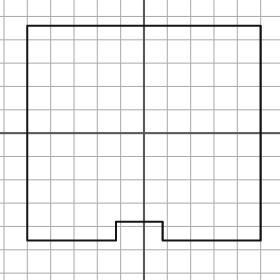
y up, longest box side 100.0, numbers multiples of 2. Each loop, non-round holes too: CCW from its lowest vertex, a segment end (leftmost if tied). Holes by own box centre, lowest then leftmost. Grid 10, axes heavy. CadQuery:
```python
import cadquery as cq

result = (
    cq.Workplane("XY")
    .moveTo(-50.0, -46.0)
    .lineTo(-12.0, -46.0)
    .lineTo(-12.0, -38.0)
    .lineTo(8.0, -38.0)
    .lineTo(8.0, -46.0)
    .lineTo(50.0, -46.0)
    .lineTo(50.0, 46.0)
    .lineTo(-50.0, 46.0)
    .close()
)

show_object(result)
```